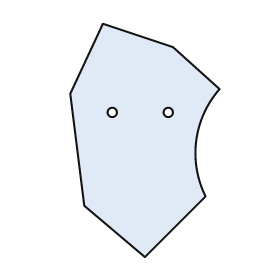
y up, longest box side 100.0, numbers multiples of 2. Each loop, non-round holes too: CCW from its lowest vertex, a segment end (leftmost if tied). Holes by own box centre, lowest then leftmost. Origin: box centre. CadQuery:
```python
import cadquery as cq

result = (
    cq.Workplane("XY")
    .moveTo(0.0, -50.0)
    .lineTo(26.0, -24.0)
    .threePointArc((22.0, 0.0), (32.0, 22.0))
    .lineTo(12.0, 40.0)
    .lineTo(-18.0, 50.0)
    .lineTo(-32.0, 20.0)
    .lineTo(-26.0, -28.0)
    .close()
    .moveTo(-14.0, 12.0)
    .circle(2.0)
    .moveTo(10.0, 12.0)
    .circle(2.0)
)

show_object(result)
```